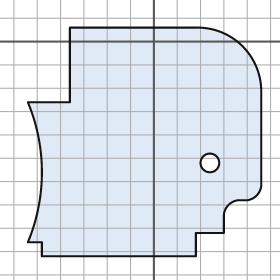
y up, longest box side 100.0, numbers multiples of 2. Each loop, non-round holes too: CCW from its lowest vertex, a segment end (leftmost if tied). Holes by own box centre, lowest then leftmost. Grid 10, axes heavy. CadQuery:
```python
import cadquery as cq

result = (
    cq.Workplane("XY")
    .moveTo(-48.0, -92.0)
    .lineTo(18.0, -92.0)
    .lineTo(18.0, -82.0)
    .lineTo(30.0, -82.0)
    .lineTo(30.0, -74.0)
    .threePointArc((32.0, -70.0), (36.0, -68.0))
    .lineTo(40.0, -68.0)
    .threePointArc((44.0, -66.0), (46.0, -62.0))
    .lineTo(46.0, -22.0)
    .threePointArc((38.0, -2.0), (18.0, 6.0))
    .lineTo(-36.0, 6.0)
    .lineTo(-36.0, -26.0)
    .lineTo(-54.0, -26.0)
    .threePointArc((-48.0, -56.0), (-54.0, -86.0))
    .lineTo(-48.0, -86.0)
    .close()
    .moveTo(24.0, -52.0)
    .circle(4.0)
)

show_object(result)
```